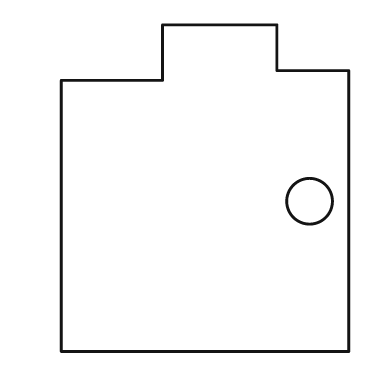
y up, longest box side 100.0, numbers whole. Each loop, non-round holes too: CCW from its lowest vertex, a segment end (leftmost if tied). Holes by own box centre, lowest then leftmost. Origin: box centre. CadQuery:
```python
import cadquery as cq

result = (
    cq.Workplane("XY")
    .moveTo(-44.0, -50.0)
    .lineTo(44.0, -50.0)
    .lineTo(44.0, 36.0)
    .lineTo(22.0, 36.0)
    .lineTo(22.0, 50.0)
    .lineTo(-13.0, 50.0)
    .lineTo(-13.0, 33.0)
    .lineTo(-44.0, 33.0)
    .close()
    .moveTo(32.0, -4.0)
    .circle(7.0)
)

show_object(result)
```